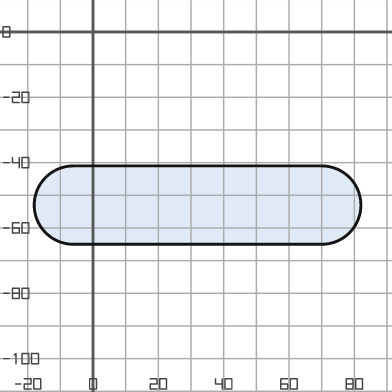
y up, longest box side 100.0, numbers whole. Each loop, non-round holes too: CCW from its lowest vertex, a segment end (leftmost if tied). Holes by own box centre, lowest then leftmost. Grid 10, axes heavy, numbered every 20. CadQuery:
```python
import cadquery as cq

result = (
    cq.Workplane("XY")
    .moveTo(-6.0, -65.0)
    .lineTo(70.0, -65.0)
    .threePointArc((82.0, -53.0), (70.0, -41.0))
    .lineTo(-6.0, -41.0)
    .threePointArc((-18.0, -53.0), (-6.0, -65.0))
    .close()
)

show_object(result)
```